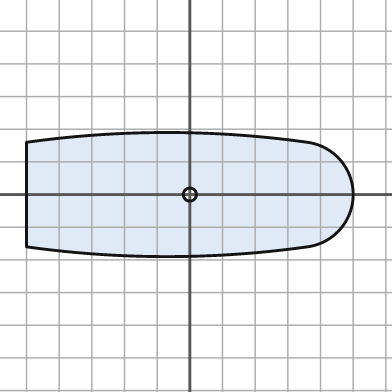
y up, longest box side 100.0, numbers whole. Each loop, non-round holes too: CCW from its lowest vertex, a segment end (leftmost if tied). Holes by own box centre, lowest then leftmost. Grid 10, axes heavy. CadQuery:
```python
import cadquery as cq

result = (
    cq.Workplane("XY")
    .moveTo(-50.0, -16.0)
    .threePointArc((-7.0, -19.0), (36.0, -16.0))
    .threePointArc((50.0, 0.0), (36.0, 16.0))
    .threePointArc((-7.0, 19.0), (-50.0, 16.0))
    .close()
    .moveTo(0.0, 0.0)
    .circle(2.0)
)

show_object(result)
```